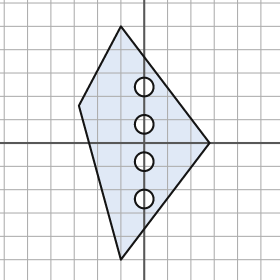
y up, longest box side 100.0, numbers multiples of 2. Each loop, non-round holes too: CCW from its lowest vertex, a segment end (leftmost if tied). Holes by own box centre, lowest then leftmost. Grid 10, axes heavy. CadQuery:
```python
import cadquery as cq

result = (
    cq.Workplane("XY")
    .moveTo(-10.0, -50.0)
    .lineTo(28.0, 0.0)
    .lineTo(-10.0, 50.0)
    .lineTo(-28.0, 16.0)
    .close()
    .moveTo(0.0, -24.0)
    .circle(4.0)
    .moveTo(0.0, -8.0)
    .circle(4.0)
    .moveTo(0.0, 8.0)
    .circle(4.0)
    .moveTo(0.0, 24.0)
    .circle(4.0)
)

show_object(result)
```